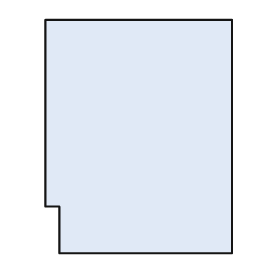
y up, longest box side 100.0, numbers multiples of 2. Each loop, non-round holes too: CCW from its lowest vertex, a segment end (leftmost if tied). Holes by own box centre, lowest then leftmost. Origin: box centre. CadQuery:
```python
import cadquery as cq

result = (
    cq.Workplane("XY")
    .moveTo(-34.0, -50.0)
    .lineTo(40.0, -50.0)
    .lineTo(40.0, 50.0)
    .lineTo(-40.0, 50.0)
    .lineTo(-40.0, -30.0)
    .lineTo(-34.0, -30.0)
    .close()
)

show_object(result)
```